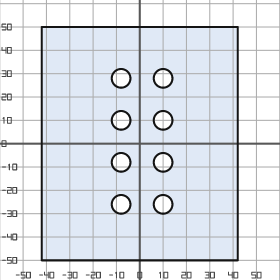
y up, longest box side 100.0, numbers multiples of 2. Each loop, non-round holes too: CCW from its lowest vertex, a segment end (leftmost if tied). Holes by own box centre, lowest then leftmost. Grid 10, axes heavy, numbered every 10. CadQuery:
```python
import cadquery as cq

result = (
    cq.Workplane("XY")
    .moveTo(-42.0, -50.0)
    .lineTo(42.0, -50.0)
    .lineTo(42.0, 50.0)
    .lineTo(-42.0, 50.0)
    .close()
    .moveTo(-8.0, -26.0)
    .circle(4.0)
    .moveTo(10.0, -26.0)
    .circle(4.0)
    .moveTo(-8.0, -8.0)
    .circle(4.0)
    .moveTo(10.0, -8.0)
    .circle(4.0)
    .moveTo(-8.0, 10.0)
    .circle(4.0)
    .moveTo(10.0, 10.0)
    .circle(4.0)
    .moveTo(-8.0, 28.0)
    .circle(4.0)
    .moveTo(10.0, 28.0)
    .circle(4.0)
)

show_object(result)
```